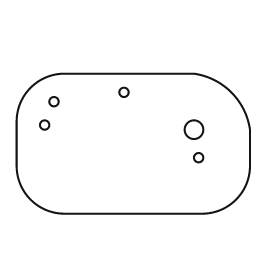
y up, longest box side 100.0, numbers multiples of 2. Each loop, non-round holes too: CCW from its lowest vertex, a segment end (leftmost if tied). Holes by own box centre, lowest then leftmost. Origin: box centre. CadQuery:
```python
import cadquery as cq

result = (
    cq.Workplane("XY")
    .moveTo(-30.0, -30.0)
    .lineTo(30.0, -30.0)
    .threePointArc((44.0, -24.0), (50.0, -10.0))
    .lineTo(50.0, 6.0)
    .threePointArc((42.0, 22.0), (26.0, 30.0))
    .lineTo(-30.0, 30.0)
    .threePointArc((-44.0, 24.0), (-50.0, 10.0))
    .lineTo(-50.0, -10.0)
    .threePointArc((-44.0, -24.0), (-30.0, -30.0))
    .close()
    .moveTo(28.0, -6.0)
    .circle(2.0)
    .moveTo(26.0, 6.0)
    .circle(4.0)
    .moveTo(-38.0, 8.0)
    .circle(2.0)
    .moveTo(-34.0, 18.0)
    .circle(2.0)
    .moveTo(-4.0, 22.0)
    .circle(2.0)
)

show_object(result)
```